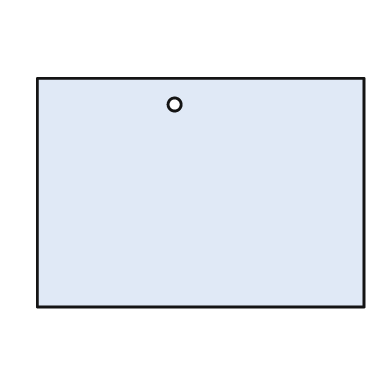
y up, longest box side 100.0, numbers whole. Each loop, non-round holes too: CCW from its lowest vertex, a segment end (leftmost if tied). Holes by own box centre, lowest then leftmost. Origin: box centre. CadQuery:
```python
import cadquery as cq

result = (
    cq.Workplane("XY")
    .moveTo(-50.0, -35.0)
    .lineTo(50.0, -35.0)
    .lineTo(50.0, 35.0)
    .lineTo(-50.0, 35.0)
    .close()
    .moveTo(-8.0, 27.0)
    .circle(2.0)
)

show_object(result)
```